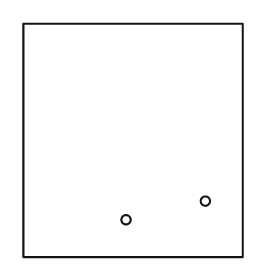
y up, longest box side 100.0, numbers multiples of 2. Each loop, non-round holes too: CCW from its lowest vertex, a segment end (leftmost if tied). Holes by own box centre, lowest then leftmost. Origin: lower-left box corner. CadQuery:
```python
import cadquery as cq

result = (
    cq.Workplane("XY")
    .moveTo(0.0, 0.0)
    .lineTo(94.0, 0.0)
    .lineTo(94.0, 100.0)
    .lineTo(0.0, 100.0)
    .close()
    .moveTo(44.0, 16.0)
    .circle(2.0)
    .moveTo(78.0, 24.0)
    .circle(2.0)
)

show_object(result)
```